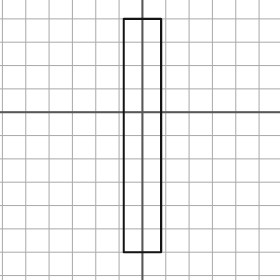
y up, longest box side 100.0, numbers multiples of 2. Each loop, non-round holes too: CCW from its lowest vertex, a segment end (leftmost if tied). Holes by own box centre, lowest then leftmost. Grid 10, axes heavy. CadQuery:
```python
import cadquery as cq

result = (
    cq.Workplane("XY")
    .moveTo(-8.0, -60.0)
    .lineTo(8.0, -60.0)
    .lineTo(8.0, 40.0)
    .lineTo(-8.0, 40.0)
    .close()
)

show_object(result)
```